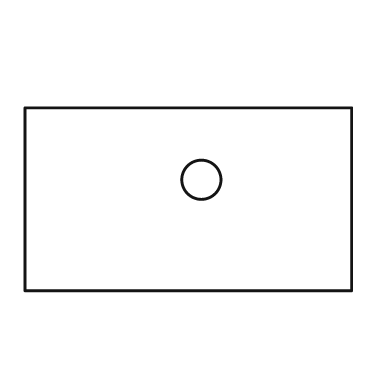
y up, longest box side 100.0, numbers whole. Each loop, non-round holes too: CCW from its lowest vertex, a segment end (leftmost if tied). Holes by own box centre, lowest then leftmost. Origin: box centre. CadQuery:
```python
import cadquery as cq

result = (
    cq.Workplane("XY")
    .moveTo(-50.0, -28.0)
    .lineTo(50.0, -28.0)
    .lineTo(50.0, 28.0)
    .lineTo(-50.0, 28.0)
    .close()
    .moveTo(4.0, 6.0)
    .circle(6.0)
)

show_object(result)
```